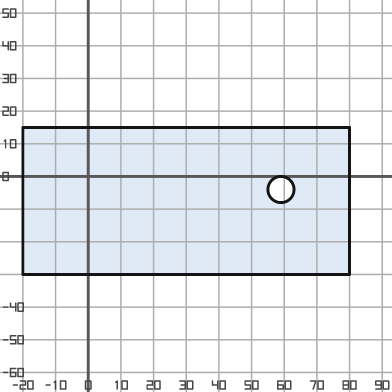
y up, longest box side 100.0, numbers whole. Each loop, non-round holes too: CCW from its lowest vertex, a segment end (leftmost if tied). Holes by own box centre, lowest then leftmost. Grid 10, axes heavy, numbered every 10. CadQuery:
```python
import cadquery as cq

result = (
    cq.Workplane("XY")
    .moveTo(-20.0, -30.0)
    .lineTo(80.0, -30.0)
    .lineTo(80.0, 15.0)
    .lineTo(-20.0, 15.0)
    .close()
    .moveTo(59.0, -4.0)
    .circle(4.0)
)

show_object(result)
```